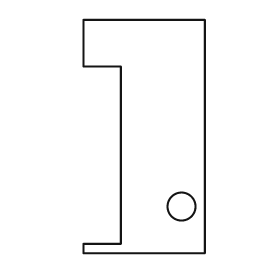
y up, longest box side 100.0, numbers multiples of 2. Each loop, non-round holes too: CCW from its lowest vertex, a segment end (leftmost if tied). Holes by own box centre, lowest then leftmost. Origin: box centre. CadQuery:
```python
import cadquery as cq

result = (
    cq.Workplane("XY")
    .moveTo(-26.0, -50.0)
    .lineTo(26.0, -50.0)
    .lineTo(26.0, 50.0)
    .lineTo(-26.0, 50.0)
    .lineTo(-26.0, 30.0)
    .lineTo(-10.0, 30.0)
    .lineTo(-10.0, -46.0)
    .lineTo(-26.0, -46.0)
    .close()
    .moveTo(16.0, -30.0)
    .circle(6.0)
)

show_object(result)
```